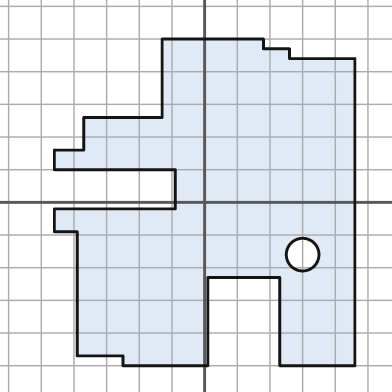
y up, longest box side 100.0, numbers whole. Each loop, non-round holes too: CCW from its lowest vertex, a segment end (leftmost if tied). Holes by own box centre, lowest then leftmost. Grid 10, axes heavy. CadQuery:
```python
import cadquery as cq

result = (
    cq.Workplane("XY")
    .moveTo(-25.0, -50.0)
    .lineTo(1.0, -50.0)
    .lineTo(1.0, -23.0)
    .lineTo(23.0, -23.0)
    .lineTo(23.0, -50.0)
    .lineTo(46.0, -50.0)
    .lineTo(46.0, 44.0)
    .lineTo(26.0, 44.0)
    .lineTo(26.0, 47.0)
    .lineTo(18.0, 47.0)
    .lineTo(18.0, 50.0)
    .lineTo(-13.0, 50.0)
    .lineTo(-13.0, 26.0)
    .lineTo(-37.0, 26.0)
    .lineTo(-37.0, 16.0)
    .lineTo(-46.0, 16.0)
    .lineTo(-46.0, 10.0)
    .lineTo(-9.0, 10.0)
    .lineTo(-9.0, -2.0)
    .lineTo(-46.0, -2.0)
    .lineTo(-46.0, -9.0)
    .lineTo(-39.0, -9.0)
    .lineTo(-39.0, -47.0)
    .lineTo(-25.0, -47.0)
    .close()
    .moveTo(30.0, -16.0)
    .circle(5.0)
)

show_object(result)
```